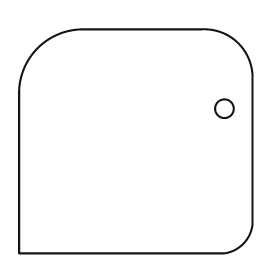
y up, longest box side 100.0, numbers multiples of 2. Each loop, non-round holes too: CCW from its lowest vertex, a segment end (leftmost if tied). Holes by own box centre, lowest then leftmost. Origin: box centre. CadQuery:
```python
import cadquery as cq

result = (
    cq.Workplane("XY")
    .moveTo(-50.0, -48.0)
    .lineTo(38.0, -48.0)
    .threePointArc((46.0, -44.0), (50.0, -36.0))
    .lineTo(50.0, 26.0)
    .threePointArc((44.0, 42.0), (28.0, 48.0))
    .lineTo(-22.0, 48.0)
    .threePointArc((-42.0, 40.0), (-50.0, 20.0))
    .close()
    .moveTo(38.0, 14.0)
    .circle(4.0)
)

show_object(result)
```